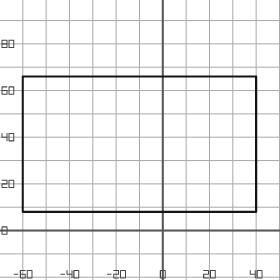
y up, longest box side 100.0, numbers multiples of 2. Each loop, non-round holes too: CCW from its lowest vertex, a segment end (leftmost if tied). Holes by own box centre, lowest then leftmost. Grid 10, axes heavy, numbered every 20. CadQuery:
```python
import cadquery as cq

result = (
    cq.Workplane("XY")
    .moveTo(-60.0, 8.0)
    .lineTo(40.0, 8.0)
    .lineTo(40.0, 66.0)
    .lineTo(-60.0, 66.0)
    .close()
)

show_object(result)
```